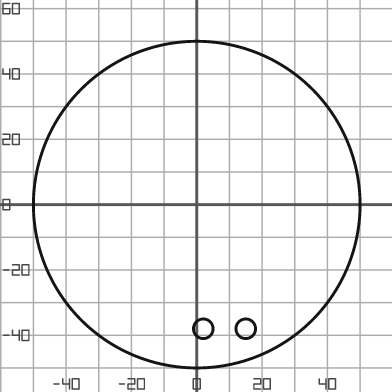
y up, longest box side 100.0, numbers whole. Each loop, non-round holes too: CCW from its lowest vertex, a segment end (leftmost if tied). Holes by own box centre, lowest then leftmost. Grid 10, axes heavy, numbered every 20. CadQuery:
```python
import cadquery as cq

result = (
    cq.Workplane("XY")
    .moveTo(0.0, 0.0)
    .circle(50.0)
    .moveTo(2.0, -38.0)
    .circle(3.0)
    .moveTo(15.0, -38.0)
    .circle(3.0)
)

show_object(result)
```